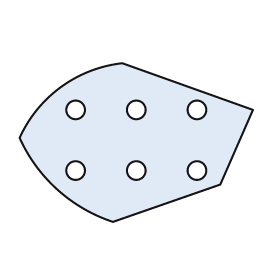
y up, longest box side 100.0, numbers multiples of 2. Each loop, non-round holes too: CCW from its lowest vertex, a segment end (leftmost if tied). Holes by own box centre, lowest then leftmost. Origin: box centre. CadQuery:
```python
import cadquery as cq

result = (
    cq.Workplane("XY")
    .moveTo(-10.0, -34.0)
    .lineTo(36.0, -18.0)
    .lineTo(50.0, 14.0)
    .lineTo(-6.0, 34.0)
    .threePointArc((-32.0, 24.0), (-50.0, 2.0))
    .threePointArc((-34.0, -20.0), (-10.0, -34.0))
    .close()
    .moveTo(-26.0, -12.0)
    .circle(4.0)
    .moveTo(0.0, -12.0)
    .circle(4.0)
    .moveTo(26.0, -12.0)
    .circle(4.0)
    .moveTo(-26.0, 14.0)
    .circle(4.0)
    .moveTo(0.0, 14.0)
    .circle(4.0)
    .moveTo(26.0, 14.0)
    .circle(4.0)
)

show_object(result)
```